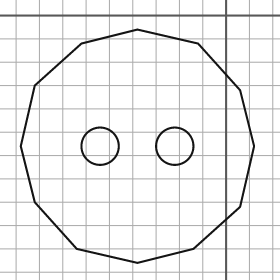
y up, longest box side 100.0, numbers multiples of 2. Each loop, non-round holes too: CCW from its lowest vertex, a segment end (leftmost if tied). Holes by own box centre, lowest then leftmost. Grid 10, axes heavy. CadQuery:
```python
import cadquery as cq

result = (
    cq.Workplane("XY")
    .moveTo(-38.0, -106.0)
    .lineTo(-14.0, -100.0)
    .lineTo(6.0, -82.0)
    .lineTo(12.0, -56.0)
    .lineTo(6.0, -32.0)
    .lineTo(-12.0, -12.0)
    .lineTo(-38.0, -6.0)
    .lineTo(-62.0, -12.0)
    .lineTo(-82.0, -30.0)
    .lineTo(-88.0, -56.0)
    .lineTo(-82.0, -80.0)
    .lineTo(-64.0, -100.0)
    .close()
    .moveTo(-54.0, -56.0)
    .circle(8.0)
    .moveTo(-22.0, -56.0)
    .circle(8.0)
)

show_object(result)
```